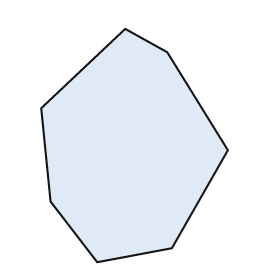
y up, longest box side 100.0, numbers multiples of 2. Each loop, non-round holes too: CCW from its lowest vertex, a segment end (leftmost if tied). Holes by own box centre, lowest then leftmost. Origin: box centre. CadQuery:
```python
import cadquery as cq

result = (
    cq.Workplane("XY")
    .moveTo(-16.0, -50.0)
    .lineTo(16.0, -44.0)
    .lineTo(40.0, -2.0)
    .lineTo(14.0, 40.0)
    .lineTo(-4.0, 50.0)
    .lineTo(-40.0, 16.0)
    .lineTo(-36.0, -24.0)
    .close()
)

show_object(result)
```